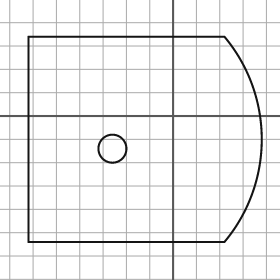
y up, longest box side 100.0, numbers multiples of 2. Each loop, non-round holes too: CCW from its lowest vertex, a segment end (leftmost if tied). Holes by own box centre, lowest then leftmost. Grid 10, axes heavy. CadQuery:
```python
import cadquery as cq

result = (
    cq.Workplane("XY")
    .moveTo(-62.0, -54.0)
    .lineTo(22.0, -54.0)
    .threePointArc((38.0, -10.0), (22.0, 34.0))
    .lineTo(-62.0, 34.0)
    .close()
    .moveTo(-26.0, -14.0)
    .circle(6.0)
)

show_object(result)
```